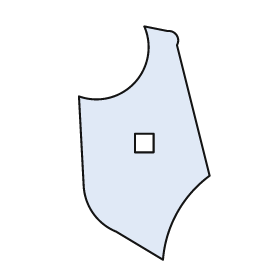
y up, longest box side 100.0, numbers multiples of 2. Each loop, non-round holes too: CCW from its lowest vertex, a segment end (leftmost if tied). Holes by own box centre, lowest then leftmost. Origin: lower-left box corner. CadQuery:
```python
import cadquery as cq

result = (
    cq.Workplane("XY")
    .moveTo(36.0, 0.0)
    .threePointArc((42.0, 20.0), (56.0, 36.0))
    .lineTo(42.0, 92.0)
    .threePointArc((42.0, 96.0), (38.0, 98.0))
    .lineTo(28.0, 100.0)
    .threePointArc((24.0, 76.0), (0.0, 70.0))
    .lineTo(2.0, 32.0)
    .threePointArc((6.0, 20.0), (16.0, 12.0))
    .close()
    .moveTo(24.0, 46.0)
    .lineTo(32.0, 46.0)
    .lineTo(32.0, 54.0)
    .lineTo(24.0, 54.0)
    .close()
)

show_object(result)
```